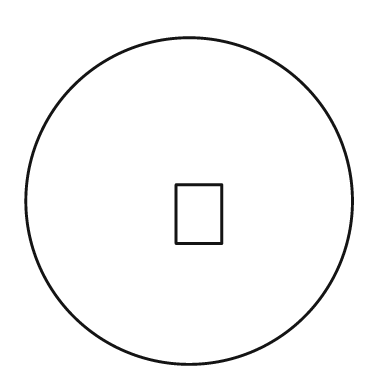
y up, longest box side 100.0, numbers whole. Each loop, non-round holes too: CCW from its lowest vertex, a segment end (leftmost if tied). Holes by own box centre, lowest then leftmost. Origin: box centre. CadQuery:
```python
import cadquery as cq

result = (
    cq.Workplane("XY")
    .moveTo(0.0, 0.0)
    .circle(50.0)
    .moveTo(-4.0, -13.0)
    .lineTo(10.0, -13.0)
    .lineTo(10.0, 5.0)
    .lineTo(-4.0, 5.0)
    .close()
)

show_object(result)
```